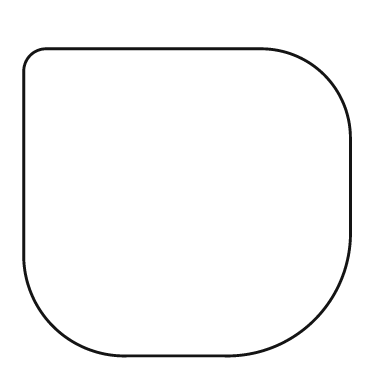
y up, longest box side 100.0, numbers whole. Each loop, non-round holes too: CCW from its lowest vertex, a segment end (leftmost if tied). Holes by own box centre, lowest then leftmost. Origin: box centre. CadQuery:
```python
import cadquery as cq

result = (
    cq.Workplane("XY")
    .moveTo(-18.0, -47.0)
    .lineTo(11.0, -47.0)
    .threePointArc((39.0, -36.0), (50.0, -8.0))
    .lineTo(50.0, 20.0)
    .threePointArc((42.0, 39.0), (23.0, 47.0))
    .lineTo(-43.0, 47.0)
    .threePointArc((-48.0, 45.0), (-50.0, 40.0))
    .lineTo(-50.0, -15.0)
    .threePointArc((-41.0, -38.0), (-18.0, -47.0))
    .close()
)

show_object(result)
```